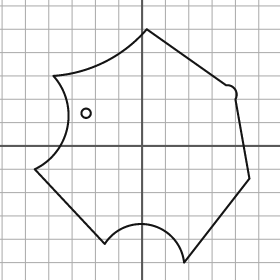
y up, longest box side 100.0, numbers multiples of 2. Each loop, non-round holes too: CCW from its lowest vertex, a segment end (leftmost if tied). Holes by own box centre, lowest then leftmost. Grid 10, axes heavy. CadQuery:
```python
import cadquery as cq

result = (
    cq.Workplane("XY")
    .moveTo(18.0, -50.0)
    .lineTo(46.0, -14.0)
    .lineTo(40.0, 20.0)
    .threePointArc((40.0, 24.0), (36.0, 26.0))
    .lineTo(2.0, 50.0)
    .threePointArc((-16.0, 36.0), (-38.0, 30.0))
    .threePointArc((-32.0, 8.0), (-46.0, -10.0))
    .lineTo(-16.0, -42.0)
    .threePointArc((4.0, -34.0), (18.0, -50.0))
    .close()
    .moveTo(-24.0, 14.0)
    .circle(2.0)
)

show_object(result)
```